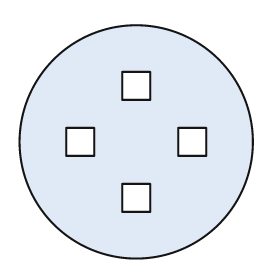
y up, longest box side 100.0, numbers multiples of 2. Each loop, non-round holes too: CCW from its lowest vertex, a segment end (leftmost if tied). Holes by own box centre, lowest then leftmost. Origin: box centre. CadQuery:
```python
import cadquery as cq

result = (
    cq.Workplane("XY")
    .moveTo(0.0, 0.0)
    .circle(50.0)
    .moveTo(-6.0, -30.0)
    .lineTo(6.0, -30.0)
    .lineTo(6.0, -18.0)
    .lineTo(-6.0, -18.0)
    .close()
    .moveTo(-30.0, -6.0)
    .lineTo(-18.0, -6.0)
    .lineTo(-18.0, 6.0)
    .lineTo(-30.0, 6.0)
    .close()
    .moveTo(18.0, -6.0)
    .lineTo(30.0, -6.0)
    .lineTo(30.0, 6.0)
    .lineTo(18.0, 6.0)
    .close()
    .moveTo(-6.0, 18.0)
    .lineTo(6.0, 18.0)
    .lineTo(6.0, 30.0)
    .lineTo(-6.0, 30.0)
    .close()
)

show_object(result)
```